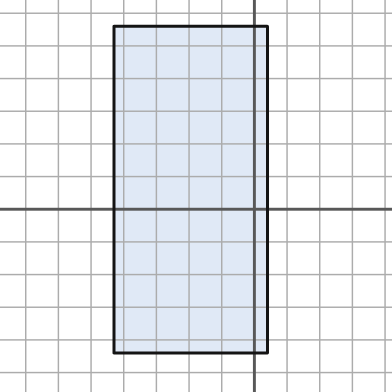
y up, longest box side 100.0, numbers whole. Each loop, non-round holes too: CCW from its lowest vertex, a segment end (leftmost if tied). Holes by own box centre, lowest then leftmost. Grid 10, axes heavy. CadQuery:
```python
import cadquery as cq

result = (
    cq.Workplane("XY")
    .moveTo(-43.0, -44.0)
    .lineTo(4.0, -44.0)
    .lineTo(4.0, 56.0)
    .lineTo(-43.0, 56.0)
    .close()
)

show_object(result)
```